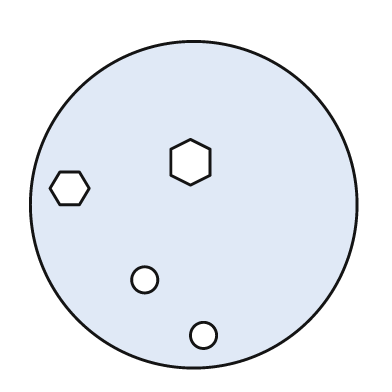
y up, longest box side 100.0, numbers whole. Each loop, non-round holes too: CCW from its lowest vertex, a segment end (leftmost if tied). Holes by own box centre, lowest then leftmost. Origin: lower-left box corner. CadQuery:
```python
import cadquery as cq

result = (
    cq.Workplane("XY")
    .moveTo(50.0, 50.0)
    .circle(50.0)
    .moveTo(53.0, 10.0)
    .circle(4.0)
    .moveTo(35.0, 27.0)
    .circle(4.0)
    .moveTo(9.0, 50.0)
    .lineTo(15.0, 50.0)
    .lineTo(18.0, 55.0)
    .lineTo(15.0, 60.0)
    .lineTo(9.0, 60.0)
    .lineTo(6.0, 55.0)
    .close()
    .moveTo(49.0, 56.0)
    .lineTo(55.0, 59.0)
    .lineTo(55.0, 67.0)
    .lineTo(49.0, 70.0)
    .lineTo(43.0, 67.0)
    .lineTo(43.0, 59.0)
    .close()
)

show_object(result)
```